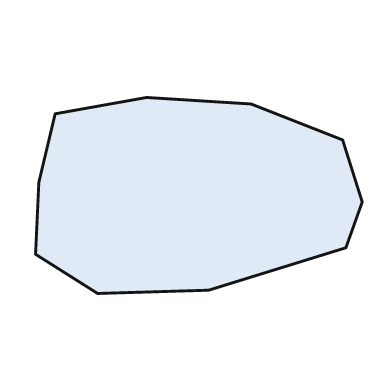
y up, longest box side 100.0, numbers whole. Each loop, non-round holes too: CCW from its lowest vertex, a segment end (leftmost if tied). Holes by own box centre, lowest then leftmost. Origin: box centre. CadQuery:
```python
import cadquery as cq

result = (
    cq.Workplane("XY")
    .moveTo(-31.0, -30.0)
    .lineTo(3.0, -29.0)
    .lineTo(45.0, -16.0)
    .lineTo(50.0, -2.0)
    .lineTo(44.0, 17.0)
    .lineTo(16.0, 28.0)
    .lineTo(-16.0, 30.0)
    .lineTo(-44.0, 25.0)
    .lineTo(-49.0, 4.0)
    .lineTo(-50.0, -18.0)
    .close()
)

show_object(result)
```